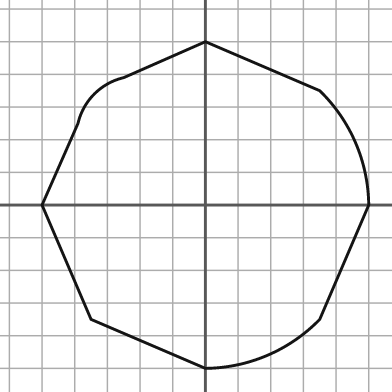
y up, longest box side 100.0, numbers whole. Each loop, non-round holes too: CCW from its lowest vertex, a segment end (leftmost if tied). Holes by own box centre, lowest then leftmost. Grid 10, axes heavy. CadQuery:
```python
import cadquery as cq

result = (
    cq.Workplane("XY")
    .moveTo(0.0, -50.0)
    .threePointArc((19.0, -46.0), (35.0, -35.0))
    .lineTo(50.0, 0.0)
    .threePointArc((46.0, 19.0), (35.0, 35.0))
    .lineTo(0.0, 50.0)
    .lineTo(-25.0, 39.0)
    .threePointArc((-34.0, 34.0), (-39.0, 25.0))
    .lineTo(-50.0, 0.0)
    .lineTo(-35.0, -35.0)
    .close()
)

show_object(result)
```